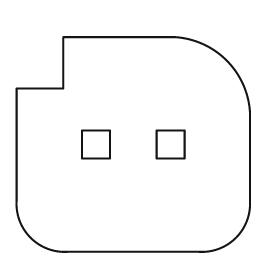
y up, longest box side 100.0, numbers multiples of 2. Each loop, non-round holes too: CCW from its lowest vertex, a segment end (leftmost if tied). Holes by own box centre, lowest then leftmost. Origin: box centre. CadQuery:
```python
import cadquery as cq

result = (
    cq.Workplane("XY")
    .moveTo(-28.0, -46.0)
    .lineTo(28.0, -46.0)
    .threePointArc((44.0, -40.0), (50.0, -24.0))
    .lineTo(50.0, 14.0)
    .threePointArc((40.0, 36.0), (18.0, 46.0))
    .lineTo(-30.0, 46.0)
    .lineTo(-30.0, 24.0)
    .lineTo(-50.0, 24.0)
    .lineTo(-50.0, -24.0)
    .threePointArc((-44.0, -40.0), (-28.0, -46.0))
    .close()
    .moveTo(-22.0, -6.0)
    .lineTo(-10.0, -6.0)
    .lineTo(-10.0, 6.0)
    .lineTo(-22.0, 6.0)
    .close()
    .moveTo(10.0, -6.0)
    .lineTo(22.0, -6.0)
    .lineTo(22.0, 6.0)
    .lineTo(10.0, 6.0)
    .close()
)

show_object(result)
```